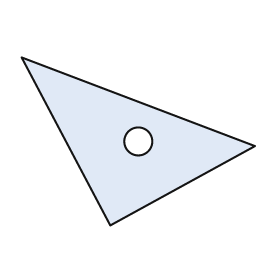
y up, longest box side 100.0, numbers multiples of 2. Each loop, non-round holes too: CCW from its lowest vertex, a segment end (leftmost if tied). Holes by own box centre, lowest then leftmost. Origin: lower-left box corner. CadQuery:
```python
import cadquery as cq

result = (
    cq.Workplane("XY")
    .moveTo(38.0, 0.0)
    .lineTo(100.0, 34.0)
    .lineTo(0.0, 72.0)
    .close()
    .moveTo(50.0, 36.0)
    .circle(6.0)
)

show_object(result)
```